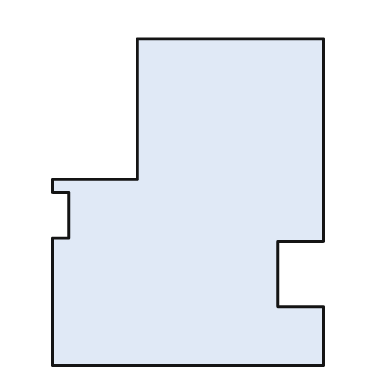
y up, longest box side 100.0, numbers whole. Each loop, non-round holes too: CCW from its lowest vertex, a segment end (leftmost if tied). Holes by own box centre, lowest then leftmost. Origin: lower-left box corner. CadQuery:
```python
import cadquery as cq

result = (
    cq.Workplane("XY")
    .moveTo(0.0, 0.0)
    .lineTo(83.0, 0.0)
    .lineTo(83.0, 18.0)
    .lineTo(69.0, 18.0)
    .lineTo(69.0, 38.0)
    .lineTo(83.0, 38.0)
    .lineTo(83.0, 100.0)
    .lineTo(26.0, 100.0)
    .lineTo(26.0, 57.0)
    .lineTo(0.0, 57.0)
    .lineTo(0.0, 53.0)
    .lineTo(5.0, 53.0)
    .lineTo(5.0, 39.0)
    .lineTo(0.0, 39.0)
    .close()
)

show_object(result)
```